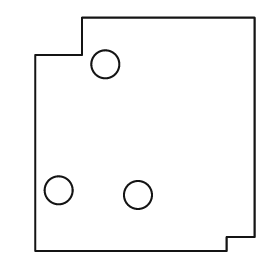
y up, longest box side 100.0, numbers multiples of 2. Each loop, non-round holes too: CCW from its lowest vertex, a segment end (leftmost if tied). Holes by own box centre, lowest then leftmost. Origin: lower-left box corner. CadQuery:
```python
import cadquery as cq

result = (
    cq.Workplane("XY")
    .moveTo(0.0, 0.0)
    .lineTo(82.0, 0.0)
    .lineTo(82.0, 6.0)
    .lineTo(94.0, 6.0)
    .lineTo(94.0, 100.0)
    .lineTo(20.0, 100.0)
    .lineTo(20.0, 84.0)
    .lineTo(0.0, 84.0)
    .close()
    .moveTo(44.0, 24.0)
    .circle(6.0)
    .moveTo(10.0, 26.0)
    .circle(6.0)
    .moveTo(30.0, 80.0)
    .circle(6.0)
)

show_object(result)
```